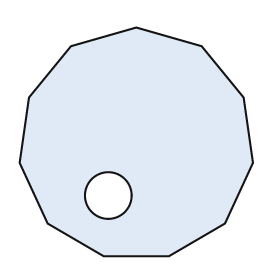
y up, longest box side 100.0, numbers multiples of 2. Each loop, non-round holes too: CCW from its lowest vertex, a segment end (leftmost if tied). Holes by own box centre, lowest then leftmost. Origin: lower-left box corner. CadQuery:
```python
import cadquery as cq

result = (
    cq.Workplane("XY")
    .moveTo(36.0, 0.0)
    .lineTo(64.0, 0.0)
    .lineTo(88.0, 14.0)
    .lineTo(100.0, 40.0)
    .lineTo(96.0, 68.0)
    .lineTo(78.0, 90.0)
    .lineTo(50.0, 98.0)
    .lineTo(22.0, 90.0)
    .lineTo(4.0, 68.0)
    .lineTo(0.0, 40.0)
    .lineTo(12.0, 14.0)
    .close()
    .moveTo(38.0, 26.0)
    .circle(10.0)
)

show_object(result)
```